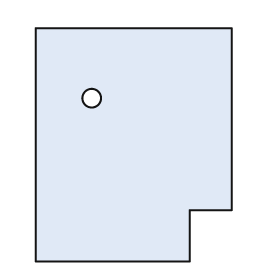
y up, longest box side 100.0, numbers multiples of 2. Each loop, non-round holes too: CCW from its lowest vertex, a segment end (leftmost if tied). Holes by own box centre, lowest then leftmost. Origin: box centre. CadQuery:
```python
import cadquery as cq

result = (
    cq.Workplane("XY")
    .moveTo(-42.0, -50.0)
    .lineTo(24.0, -50.0)
    .lineTo(24.0, -28.0)
    .lineTo(42.0, -28.0)
    .lineTo(42.0, 50.0)
    .lineTo(-42.0, 50.0)
    .close()
    .moveTo(-18.0, 20.0)
    .circle(4.0)
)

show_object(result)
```